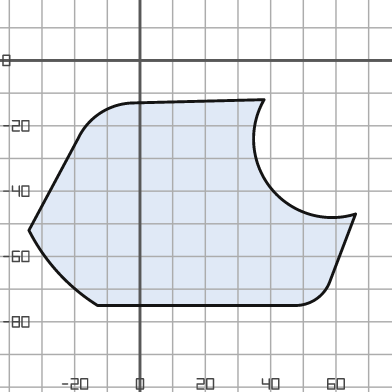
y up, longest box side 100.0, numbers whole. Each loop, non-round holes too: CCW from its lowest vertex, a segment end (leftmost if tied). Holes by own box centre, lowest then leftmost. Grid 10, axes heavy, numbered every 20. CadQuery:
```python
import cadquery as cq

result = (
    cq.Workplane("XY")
    .moveTo(-13.0, -75.0)
    .lineTo(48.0, -75.0)
    .threePointArc((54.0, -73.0), (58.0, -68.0))
    .lineTo(66.0, -47.0)
    .threePointArc((40.0, -39.0), (38.0, -12.0))
    .lineTo(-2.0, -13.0)
    .threePointArc((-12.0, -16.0), (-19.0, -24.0))
    .lineTo(-34.0, -52.0)
    .threePointArc((-25.0, -65.0), (-13.0, -75.0))
    .close()
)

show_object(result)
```